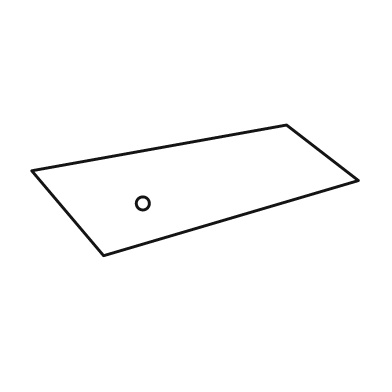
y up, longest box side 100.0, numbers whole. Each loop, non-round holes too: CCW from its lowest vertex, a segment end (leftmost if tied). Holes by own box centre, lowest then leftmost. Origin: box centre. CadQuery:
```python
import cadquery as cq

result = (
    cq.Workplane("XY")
    .moveTo(-28.0, -20.0)
    .lineTo(50.0, 3.0)
    .lineTo(28.0, 20.0)
    .lineTo(-50.0, 6.0)
    .close()
    .moveTo(-16.0, -4.0)
    .circle(2.0)
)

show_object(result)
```